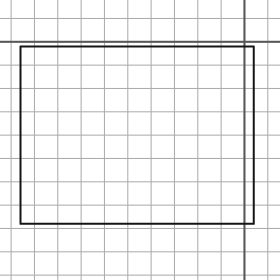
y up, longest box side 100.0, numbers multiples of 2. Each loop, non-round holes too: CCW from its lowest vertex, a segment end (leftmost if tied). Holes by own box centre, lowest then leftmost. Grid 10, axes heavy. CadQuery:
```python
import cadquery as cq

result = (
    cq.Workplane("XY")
    .moveTo(-96.0, -78.0)
    .lineTo(4.0, -78.0)
    .lineTo(4.0, -2.0)
    .lineTo(-96.0, -2.0)
    .close()
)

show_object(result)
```